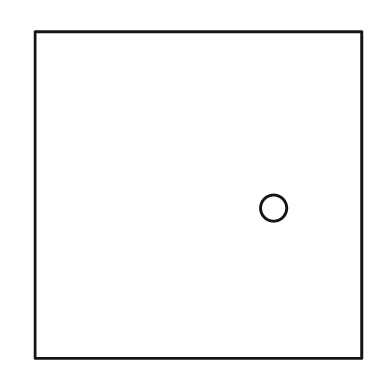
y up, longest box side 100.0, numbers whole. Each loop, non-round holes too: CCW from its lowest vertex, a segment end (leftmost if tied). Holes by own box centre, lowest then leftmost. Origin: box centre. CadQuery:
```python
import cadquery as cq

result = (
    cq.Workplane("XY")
    .moveTo(-50.0, -50.0)
    .lineTo(50.0, -50.0)
    .lineTo(50.0, 50.0)
    .lineTo(-50.0, 50.0)
    .close()
    .moveTo(23.0, -4.0)
    .circle(4.0)
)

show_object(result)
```